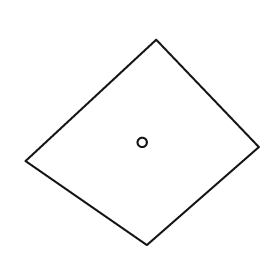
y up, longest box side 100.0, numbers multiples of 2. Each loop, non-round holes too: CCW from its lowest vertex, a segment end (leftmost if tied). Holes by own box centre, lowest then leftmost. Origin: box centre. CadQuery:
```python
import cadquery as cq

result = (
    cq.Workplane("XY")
    .moveTo(2.0, -44.0)
    .lineTo(50.0, -2.0)
    .lineTo(6.0, 44.0)
    .lineTo(-50.0, -8.0)
    .close()
    .moveTo(0.0, 0.0)
    .circle(2.0)
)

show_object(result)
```